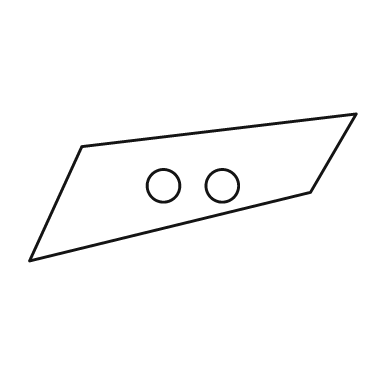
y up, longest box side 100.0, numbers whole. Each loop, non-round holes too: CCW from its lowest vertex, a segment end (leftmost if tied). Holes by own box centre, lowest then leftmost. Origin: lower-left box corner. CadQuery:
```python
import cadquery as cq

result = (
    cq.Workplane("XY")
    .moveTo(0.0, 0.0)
    .lineTo(86.0, 21.0)
    .lineTo(100.0, 45.0)
    .lineTo(16.0, 35.0)
    .close()
    .moveTo(41.0, 23.0)
    .circle(5.0)
    .moveTo(59.0, 23.0)
    .circle(5.0)
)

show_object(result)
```